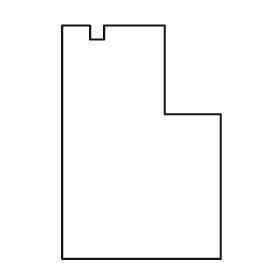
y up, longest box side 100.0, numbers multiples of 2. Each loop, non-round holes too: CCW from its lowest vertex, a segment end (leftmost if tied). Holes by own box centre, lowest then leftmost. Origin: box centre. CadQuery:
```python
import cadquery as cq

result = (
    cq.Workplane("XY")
    .moveTo(-34.0, -50.0)
    .lineTo(34.0, -50.0)
    .lineTo(34.0, 12.0)
    .lineTo(10.0, 12.0)
    .lineTo(10.0, 50.0)
    .lineTo(-16.0, 50.0)
    .lineTo(-16.0, 44.0)
    .lineTo(-22.0, 44.0)
    .lineTo(-22.0, 50.0)
    .lineTo(-34.0, 50.0)
    .close()
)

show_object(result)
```